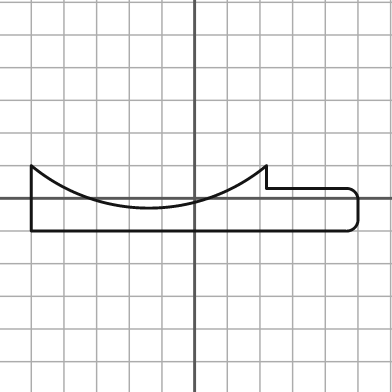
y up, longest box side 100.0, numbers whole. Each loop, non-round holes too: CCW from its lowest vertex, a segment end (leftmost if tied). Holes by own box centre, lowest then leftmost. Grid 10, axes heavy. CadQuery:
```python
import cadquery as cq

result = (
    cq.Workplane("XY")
    .moveTo(-50.0, -10.0)
    .lineTo(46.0, -10.0)
    .threePointArc((49.0, -9.0), (50.0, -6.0))
    .lineTo(50.0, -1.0)
    .threePointArc((49.0, 2.0), (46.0, 3.0))
    .lineTo(22.0, 3.0)
    .lineTo(22.0, 10.0)
    .threePointArc((-14.0, -3.0), (-50.0, 10.0))
    .close()
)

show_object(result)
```